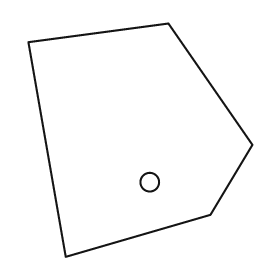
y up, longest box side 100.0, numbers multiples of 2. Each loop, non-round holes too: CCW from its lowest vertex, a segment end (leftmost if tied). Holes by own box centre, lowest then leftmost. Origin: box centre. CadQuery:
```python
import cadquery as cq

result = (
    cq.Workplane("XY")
    .moveTo(-32.0, -50.0)
    .lineTo(30.0, -32.0)
    .lineTo(48.0, -2.0)
    .lineTo(12.0, 50.0)
    .lineTo(-48.0, 42.0)
    .close()
    .moveTo(4.0, -18.0)
    .circle(4.0)
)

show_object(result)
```